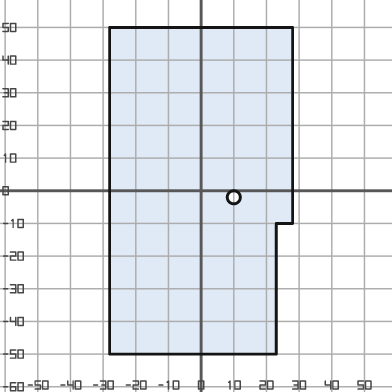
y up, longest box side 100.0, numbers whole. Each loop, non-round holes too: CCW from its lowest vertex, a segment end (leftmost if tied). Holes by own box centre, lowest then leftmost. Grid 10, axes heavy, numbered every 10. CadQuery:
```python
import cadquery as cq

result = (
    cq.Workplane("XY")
    .moveTo(-28.0, -50.0)
    .lineTo(23.0, -50.0)
    .lineTo(23.0, -10.0)
    .lineTo(28.0, -10.0)
    .lineTo(28.0, 50.0)
    .lineTo(-28.0, 50.0)
    .close()
    .moveTo(10.0, -2.0)
    .circle(2.0)
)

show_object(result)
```